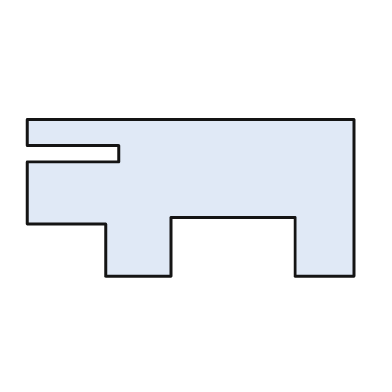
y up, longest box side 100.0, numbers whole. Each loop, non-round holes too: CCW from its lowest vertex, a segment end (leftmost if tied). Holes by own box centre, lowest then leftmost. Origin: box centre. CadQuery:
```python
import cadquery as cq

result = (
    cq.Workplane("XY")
    .moveTo(-26.0, -24.0)
    .lineTo(-6.0, -24.0)
    .lineTo(-6.0, -6.0)
    .lineTo(32.0, -6.0)
    .lineTo(32.0, -24.0)
    .lineTo(50.0, -24.0)
    .lineTo(50.0, 24.0)
    .lineTo(-50.0, 24.0)
    .lineTo(-50.0, 16.0)
    .lineTo(-22.0, 16.0)
    .lineTo(-22.0, 11.0)
    .lineTo(-50.0, 11.0)
    .lineTo(-50.0, -8.0)
    .lineTo(-26.0, -8.0)
    .close()
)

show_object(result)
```